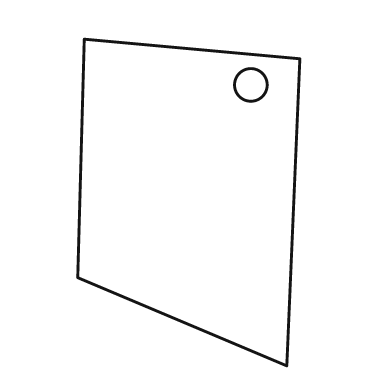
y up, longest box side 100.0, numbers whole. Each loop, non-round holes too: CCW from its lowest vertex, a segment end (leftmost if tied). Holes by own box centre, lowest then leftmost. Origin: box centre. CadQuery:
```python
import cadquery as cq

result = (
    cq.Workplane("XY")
    .moveTo(30.0, -50.0)
    .lineTo(34.0, 44.0)
    .lineTo(-32.0, 50.0)
    .lineTo(-34.0, -23.0)
    .close()
    .moveTo(19.0, 36.0)
    .circle(5.0)
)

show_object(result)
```